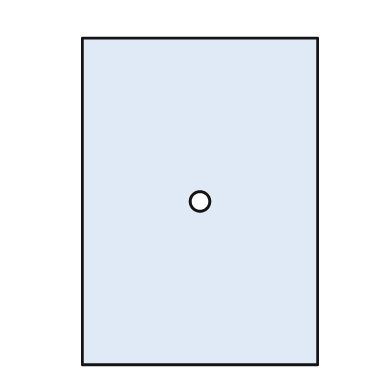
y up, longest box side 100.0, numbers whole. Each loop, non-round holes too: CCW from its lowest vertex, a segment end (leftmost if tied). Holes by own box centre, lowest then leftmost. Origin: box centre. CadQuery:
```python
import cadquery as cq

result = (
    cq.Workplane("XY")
    .moveTo(-36.0, -50.0)
    .lineTo(36.0, -50.0)
    .lineTo(36.0, 50.0)
    .lineTo(-36.0, 50.0)
    .close()
    .moveTo(0.0, 0.0)
    .circle(3.0)
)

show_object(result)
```